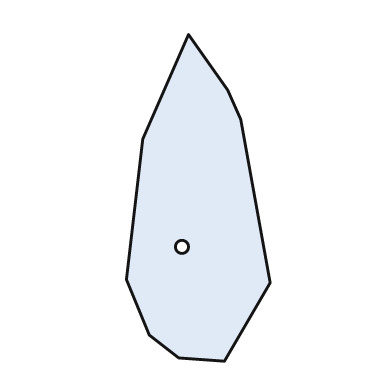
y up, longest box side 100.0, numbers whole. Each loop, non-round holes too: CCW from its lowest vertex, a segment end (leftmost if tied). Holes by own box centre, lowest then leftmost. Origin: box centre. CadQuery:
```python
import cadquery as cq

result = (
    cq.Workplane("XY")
    .moveTo(8.0, -50.0)
    .lineTo(22.0, -26.0)
    .lineTo(13.0, 24.0)
    .lineTo(9.0, 33.0)
    .lineTo(-3.0, 50.0)
    .lineTo(-17.0, 18.0)
    .lineTo(-22.0, -25.0)
    .lineTo(-15.0, -42.0)
    .lineTo(-6.0, -49.0)
    .close()
    .moveTo(-5.0, -15.0)
    .circle(2.0)
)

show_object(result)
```